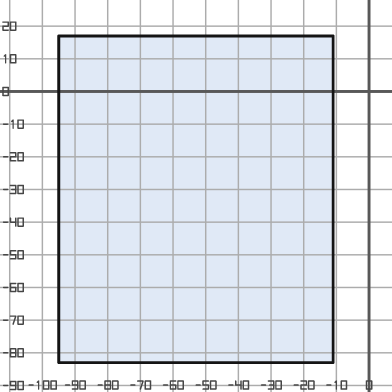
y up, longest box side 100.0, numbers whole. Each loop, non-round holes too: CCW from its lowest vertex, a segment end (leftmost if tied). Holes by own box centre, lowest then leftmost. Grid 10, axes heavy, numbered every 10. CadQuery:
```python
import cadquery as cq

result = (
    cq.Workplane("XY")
    .moveTo(-95.0, -83.0)
    .lineTo(-11.0, -83.0)
    .lineTo(-11.0, 17.0)
    .lineTo(-95.0, 17.0)
    .close()
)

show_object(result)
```